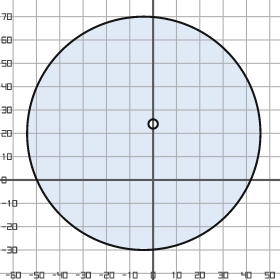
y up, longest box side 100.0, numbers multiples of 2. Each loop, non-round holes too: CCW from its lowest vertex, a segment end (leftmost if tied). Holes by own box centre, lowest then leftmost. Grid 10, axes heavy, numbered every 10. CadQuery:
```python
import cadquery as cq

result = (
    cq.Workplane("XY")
    .moveTo(-4.0, 20.0)
    .circle(50.0)
    .moveTo(0.0, 24.0)
    .circle(2.0)
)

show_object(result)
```